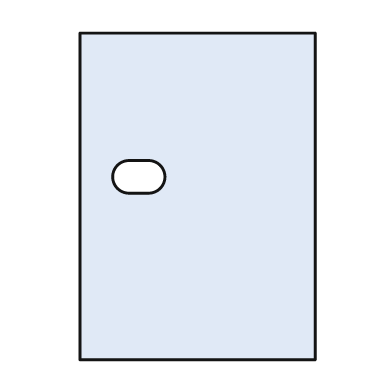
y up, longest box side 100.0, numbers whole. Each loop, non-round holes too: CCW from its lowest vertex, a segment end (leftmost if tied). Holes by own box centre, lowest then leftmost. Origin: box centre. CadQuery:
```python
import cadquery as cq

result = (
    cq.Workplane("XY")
    .moveTo(-36.0, -50.0)
    .lineTo(36.0, -50.0)
    .lineTo(36.0, 50.0)
    .lineTo(-36.0, 50.0)
    .close()
    .moveTo(-21.0, 1.0)
    .lineTo(-15.0, 1.0)
    .threePointArc((-10.0, 6.0), (-15.0, 11.0))
    .lineTo(-21.0, 11.0)
    .threePointArc((-26.0, 6.0), (-21.0, 1.0))
    .close()
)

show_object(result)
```